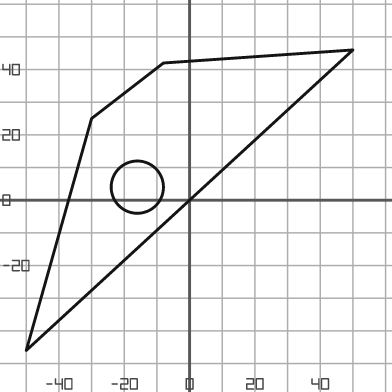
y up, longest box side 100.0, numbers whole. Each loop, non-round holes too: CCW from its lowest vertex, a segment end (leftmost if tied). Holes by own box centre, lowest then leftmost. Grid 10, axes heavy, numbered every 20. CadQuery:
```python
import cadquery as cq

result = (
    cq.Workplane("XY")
    .moveTo(-50.0, -46.0)
    .lineTo(50.0, 46.0)
    .lineTo(-8.0, 42.0)
    .lineTo(-30.0, 25.0)
    .close()
    .moveTo(-16.0, 4.0)
    .circle(8.0)
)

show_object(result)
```